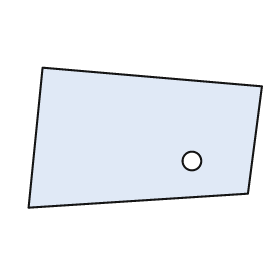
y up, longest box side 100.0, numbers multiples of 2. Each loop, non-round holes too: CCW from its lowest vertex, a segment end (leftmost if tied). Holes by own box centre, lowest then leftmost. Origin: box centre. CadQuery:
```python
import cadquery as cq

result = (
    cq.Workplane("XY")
    .moveTo(-50.0, -30.0)
    .lineTo(44.0, -24.0)
    .lineTo(50.0, 22.0)
    .lineTo(-44.0, 30.0)
    .close()
    .moveTo(20.0, -10.0)
    .circle(4.0)
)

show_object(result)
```